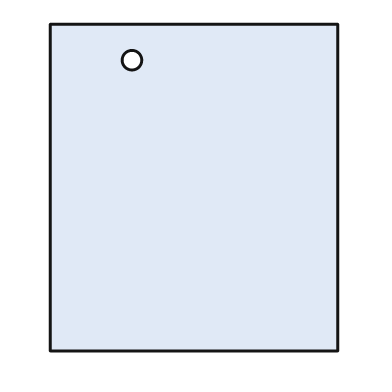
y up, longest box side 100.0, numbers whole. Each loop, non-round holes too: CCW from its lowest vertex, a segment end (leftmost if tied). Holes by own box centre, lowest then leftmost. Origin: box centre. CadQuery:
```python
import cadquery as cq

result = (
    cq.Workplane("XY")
    .moveTo(-44.0, -50.0)
    .lineTo(44.0, -50.0)
    .lineTo(44.0, 50.0)
    .lineTo(-44.0, 50.0)
    .close()
    .moveTo(-19.0, 39.0)
    .circle(3.0)
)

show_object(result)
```